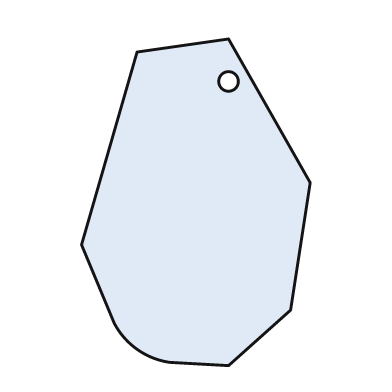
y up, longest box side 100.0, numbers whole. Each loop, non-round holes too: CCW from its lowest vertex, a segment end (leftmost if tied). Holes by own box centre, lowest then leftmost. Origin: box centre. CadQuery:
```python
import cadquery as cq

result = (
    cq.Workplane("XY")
    .moveTo(10.0, -50.0)
    .lineTo(29.0, -33.0)
    .lineTo(35.0, 6.0)
    .lineTo(10.0, 50.0)
    .lineTo(-18.0, 46.0)
    .lineTo(-35.0, -13.0)
    .lineTo(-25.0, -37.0)
    .threePointArc((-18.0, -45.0), (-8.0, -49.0))
    .close()
    .moveTo(10.0, 37.0)
    .circle(3.0)
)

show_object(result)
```